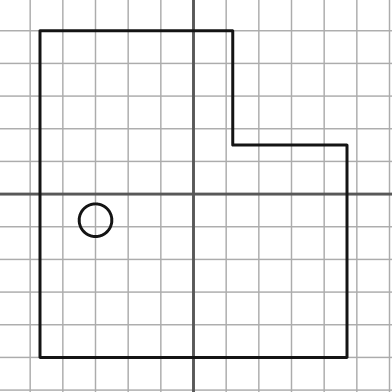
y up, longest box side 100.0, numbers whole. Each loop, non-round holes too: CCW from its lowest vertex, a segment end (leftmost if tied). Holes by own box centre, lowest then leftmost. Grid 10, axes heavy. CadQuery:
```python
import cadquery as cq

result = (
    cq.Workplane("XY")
    .moveTo(-47.0, -50.0)
    .lineTo(47.0, -50.0)
    .lineTo(47.0, 15.0)
    .lineTo(12.0, 15.0)
    .lineTo(12.0, 50.0)
    .lineTo(-47.0, 50.0)
    .close()
    .moveTo(-30.0, -8.0)
    .circle(5.0)
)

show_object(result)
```